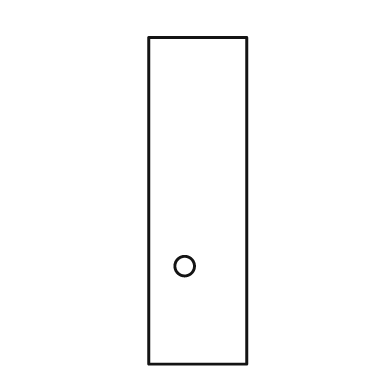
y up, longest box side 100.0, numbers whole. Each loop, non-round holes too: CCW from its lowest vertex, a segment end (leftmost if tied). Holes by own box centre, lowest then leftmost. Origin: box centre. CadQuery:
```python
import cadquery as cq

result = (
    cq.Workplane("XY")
    .moveTo(-15.0, -50.0)
    .lineTo(15.0, -50.0)
    .lineTo(15.0, 50.0)
    .lineTo(-15.0, 50.0)
    .close()
    .moveTo(-4.0, -20.0)
    .circle(3.0)
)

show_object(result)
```